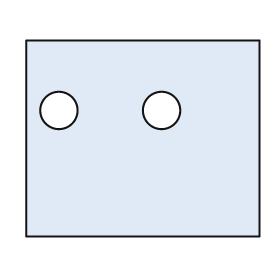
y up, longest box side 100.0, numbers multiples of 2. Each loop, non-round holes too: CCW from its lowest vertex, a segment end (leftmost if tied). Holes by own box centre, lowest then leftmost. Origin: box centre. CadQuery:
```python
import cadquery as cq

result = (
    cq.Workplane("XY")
    .moveTo(-50.0, -42.0)
    .lineTo(50.0, -42.0)
    .lineTo(50.0, 42.0)
    .lineTo(-50.0, 42.0)
    .close()
    .moveTo(-36.0, 12.0)
    .circle(8.0)
    .moveTo(8.0, 12.0)
    .circle(8.0)
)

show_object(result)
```